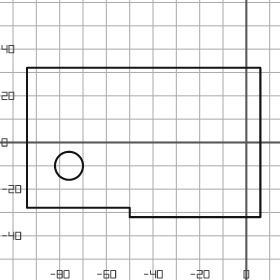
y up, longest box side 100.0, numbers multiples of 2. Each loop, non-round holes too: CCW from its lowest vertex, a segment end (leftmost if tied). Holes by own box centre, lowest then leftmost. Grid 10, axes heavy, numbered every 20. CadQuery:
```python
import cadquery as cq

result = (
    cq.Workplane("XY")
    .moveTo(-50.0, -32.0)
    .lineTo(6.0, -32.0)
    .lineTo(6.0, 32.0)
    .lineTo(-94.0, 32.0)
    .lineTo(-94.0, -28.0)
    .lineTo(-50.0, -28.0)
    .close()
    .moveTo(-76.0, -10.0)
    .circle(6.0)
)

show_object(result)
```